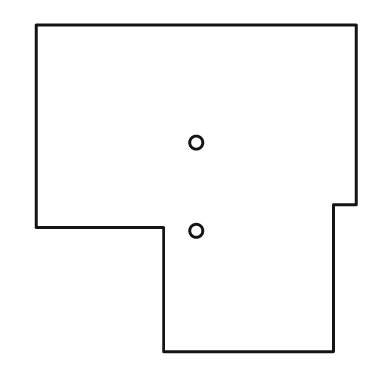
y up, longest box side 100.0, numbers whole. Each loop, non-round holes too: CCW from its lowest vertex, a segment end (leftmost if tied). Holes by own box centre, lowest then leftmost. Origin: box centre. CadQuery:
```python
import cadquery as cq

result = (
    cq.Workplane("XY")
    .moveTo(-10.0, -50.0)
    .lineTo(42.0, -50.0)
    .lineTo(42.0, -5.0)
    .lineTo(49.0, -5.0)
    .lineTo(49.0, 50.0)
    .lineTo(-49.0, 50.0)
    .lineTo(-49.0, -12.0)
    .lineTo(-10.0, -12.0)
    .close()
    .moveTo(0.0, -13.0)
    .circle(2.0)
    .moveTo(0.0, 14.0)
    .circle(2.0)
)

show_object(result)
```